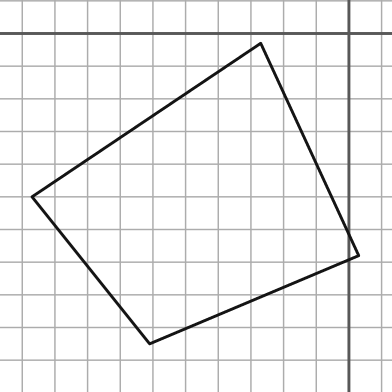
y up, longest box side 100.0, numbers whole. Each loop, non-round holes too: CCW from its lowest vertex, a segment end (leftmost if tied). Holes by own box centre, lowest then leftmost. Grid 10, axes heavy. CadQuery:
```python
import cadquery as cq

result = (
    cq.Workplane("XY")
    .moveTo(-61.0, -95.0)
    .lineTo(3.0, -68.0)
    .lineTo(-27.0, -3.0)
    .lineTo(-97.0, -50.0)
    .close()
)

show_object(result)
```